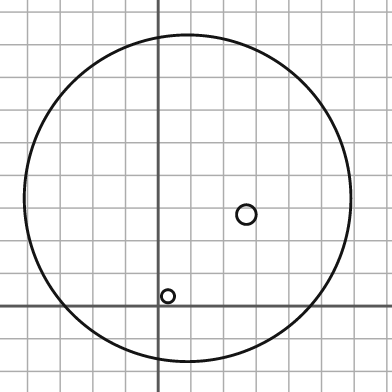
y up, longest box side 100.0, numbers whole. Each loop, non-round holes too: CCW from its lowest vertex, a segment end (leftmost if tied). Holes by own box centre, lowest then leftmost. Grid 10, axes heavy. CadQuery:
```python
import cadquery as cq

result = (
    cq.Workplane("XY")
    .moveTo(9.0, 33.0)
    .circle(50.0)
    .moveTo(3.0, 3.0)
    .circle(2.0)
    .moveTo(27.0, 28.0)
    .circle(3.0)
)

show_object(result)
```